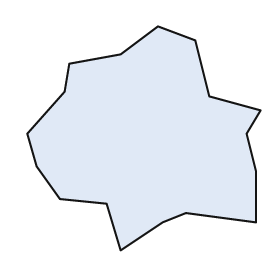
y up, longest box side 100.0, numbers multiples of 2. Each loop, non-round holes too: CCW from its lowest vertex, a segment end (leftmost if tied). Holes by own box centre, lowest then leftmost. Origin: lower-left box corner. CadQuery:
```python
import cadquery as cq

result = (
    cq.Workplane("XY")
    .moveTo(40.0, 0.0)
    .lineTo(58.0, 12.0)
    .lineTo(68.0, 16.0)
    .lineTo(98.0, 12.0)
    .lineTo(98.0, 34.0)
    .lineTo(94.0, 50.0)
    .lineTo(100.0, 60.0)
    .lineTo(78.0, 66.0)
    .lineTo(72.0, 90.0)
    .lineTo(56.0, 96.0)
    .lineTo(40.0, 84.0)
    .lineTo(18.0, 80.0)
    .lineTo(16.0, 68.0)
    .lineTo(0.0, 50.0)
    .lineTo(4.0, 36.0)
    .lineTo(14.0, 22.0)
    .lineTo(34.0, 20.0)
    .close()
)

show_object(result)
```